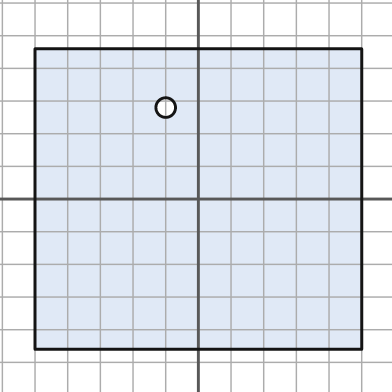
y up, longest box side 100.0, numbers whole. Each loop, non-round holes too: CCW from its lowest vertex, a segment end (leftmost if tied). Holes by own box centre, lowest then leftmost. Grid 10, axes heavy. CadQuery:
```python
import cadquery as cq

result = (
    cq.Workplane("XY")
    .moveTo(-50.0, -46.0)
    .lineTo(50.0, -46.0)
    .lineTo(50.0, 46.0)
    .lineTo(-50.0, 46.0)
    .close()
    .moveTo(-10.0, 28.0)
    .circle(3.0)
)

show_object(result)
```